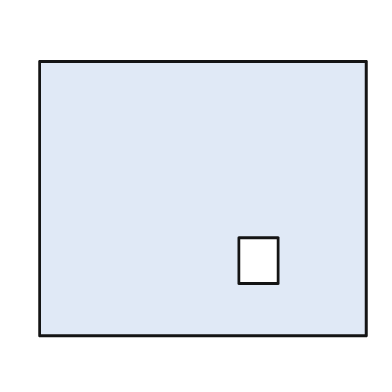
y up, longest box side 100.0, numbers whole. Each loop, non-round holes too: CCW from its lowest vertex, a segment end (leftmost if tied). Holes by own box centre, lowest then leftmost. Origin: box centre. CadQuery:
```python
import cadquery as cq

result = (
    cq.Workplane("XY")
    .moveTo(-50.0, -42.0)
    .lineTo(50.0, -42.0)
    .lineTo(50.0, 42.0)
    .lineTo(-50.0, 42.0)
    .close()
    .moveTo(11.0, -26.0)
    .lineTo(23.0, -26.0)
    .lineTo(23.0, -12.0)
    .lineTo(11.0, -12.0)
    .close()
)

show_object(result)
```